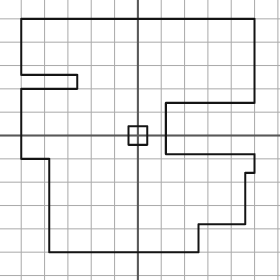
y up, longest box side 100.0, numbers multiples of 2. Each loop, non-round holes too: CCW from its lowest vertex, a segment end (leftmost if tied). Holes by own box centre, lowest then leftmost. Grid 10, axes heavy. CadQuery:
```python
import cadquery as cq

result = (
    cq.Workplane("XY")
    .moveTo(-38.0, -50.0)
    .lineTo(26.0, -50.0)
    .lineTo(26.0, -38.0)
    .lineTo(46.0, -38.0)
    .lineTo(46.0, -16.0)
    .lineTo(50.0, -16.0)
    .lineTo(50.0, -8.0)
    .lineTo(12.0, -8.0)
    .lineTo(12.0, 14.0)
    .lineTo(50.0, 14.0)
    .lineTo(50.0, 50.0)
    .lineTo(-50.0, 50.0)
    .lineTo(-50.0, 26.0)
    .lineTo(-26.0, 26.0)
    .lineTo(-26.0, 20.0)
    .lineTo(-50.0, 20.0)
    .lineTo(-50.0, -10.0)
    .lineTo(-38.0, -10.0)
    .close()
    .moveTo(-4.0, -4.0)
    .lineTo(4.0, -4.0)
    .lineTo(4.0, 4.0)
    .lineTo(-4.0, 4.0)
    .close()
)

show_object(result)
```